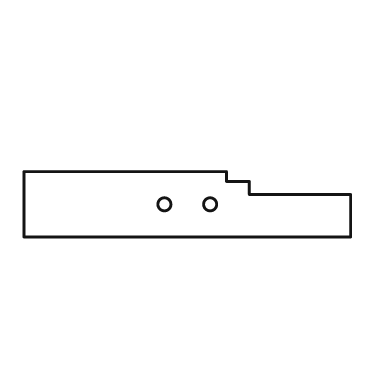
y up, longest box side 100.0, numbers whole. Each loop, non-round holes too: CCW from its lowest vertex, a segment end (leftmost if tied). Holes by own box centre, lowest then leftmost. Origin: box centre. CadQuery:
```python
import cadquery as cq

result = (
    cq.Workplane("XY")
    .moveTo(-50.0, -10.0)
    .lineTo(50.0, -10.0)
    .lineTo(50.0, 3.0)
    .lineTo(19.0, 3.0)
    .lineTo(19.0, 7.0)
    .lineTo(12.0, 7.0)
    .lineTo(12.0, 10.0)
    .lineTo(-50.0, 10.0)
    .close()
    .moveTo(-7.0, 0.0)
    .circle(2.0)
    .moveTo(7.0, 0.0)
    .circle(2.0)
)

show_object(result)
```